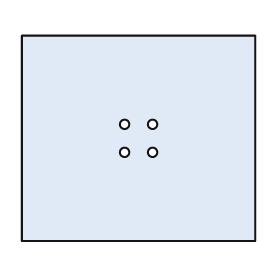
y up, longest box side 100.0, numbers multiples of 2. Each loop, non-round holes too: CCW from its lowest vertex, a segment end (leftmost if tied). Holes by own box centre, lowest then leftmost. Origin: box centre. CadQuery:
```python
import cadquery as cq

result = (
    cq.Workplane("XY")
    .moveTo(-50.0, -44.0)
    .lineTo(50.0, -44.0)
    .lineTo(50.0, 44.0)
    .lineTo(-50.0, 44.0)
    .close()
    .moveTo(-6.0, -6.0)
    .circle(2.0)
    .moveTo(6.0, -6.0)
    .circle(2.0)
    .moveTo(-6.0, 6.0)
    .circle(2.0)
    .moveTo(6.0, 6.0)
    .circle(2.0)
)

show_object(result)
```